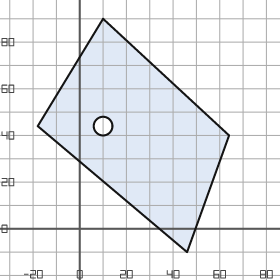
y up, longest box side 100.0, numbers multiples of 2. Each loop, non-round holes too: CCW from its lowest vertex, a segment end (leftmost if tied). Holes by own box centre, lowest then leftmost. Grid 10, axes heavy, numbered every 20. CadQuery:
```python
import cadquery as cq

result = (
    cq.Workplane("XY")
    .moveTo(46.0, -10.0)
    .lineTo(64.0, 40.0)
    .lineTo(10.0, 90.0)
    .lineTo(-18.0, 44.0)
    .close()
    .moveTo(10.0, 44.0)
    .circle(4.0)
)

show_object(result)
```